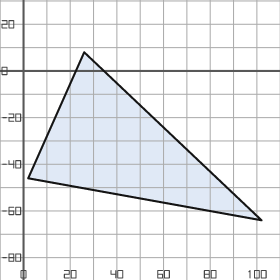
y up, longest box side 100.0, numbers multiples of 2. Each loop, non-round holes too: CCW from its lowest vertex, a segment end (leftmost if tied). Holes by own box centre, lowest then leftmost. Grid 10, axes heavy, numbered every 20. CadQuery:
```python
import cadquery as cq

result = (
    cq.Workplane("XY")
    .moveTo(102.0, -64.0)
    .lineTo(26.0, 8.0)
    .lineTo(2.0, -46.0)
    .close()
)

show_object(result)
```